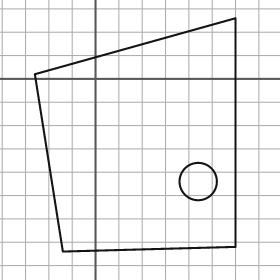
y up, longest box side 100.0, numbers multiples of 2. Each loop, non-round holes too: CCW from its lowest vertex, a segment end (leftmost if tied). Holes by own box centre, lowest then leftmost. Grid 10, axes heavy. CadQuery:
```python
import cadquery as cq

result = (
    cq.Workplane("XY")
    .moveTo(-14.0, -74.0)
    .lineTo(60.0, -72.0)
    .lineTo(60.0, 26.0)
    .lineTo(-26.0, 2.0)
    .close()
    .moveTo(44.0, -44.0)
    .circle(8.0)
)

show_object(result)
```